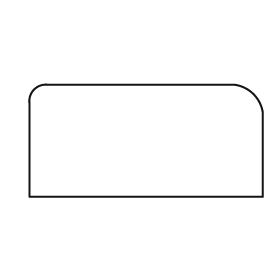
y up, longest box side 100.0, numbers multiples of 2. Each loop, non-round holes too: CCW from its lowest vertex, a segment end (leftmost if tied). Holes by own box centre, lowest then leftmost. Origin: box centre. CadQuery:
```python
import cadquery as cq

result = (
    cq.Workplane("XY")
    .moveTo(-50.0, -24.0)
    .lineTo(50.0, -24.0)
    .lineTo(50.0, 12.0)
    .threePointArc((46.0, 20.0), (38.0, 24.0))
    .lineTo(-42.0, 24.0)
    .threePointArc((-48.0, 22.0), (-50.0, 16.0))
    .close()
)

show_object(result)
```